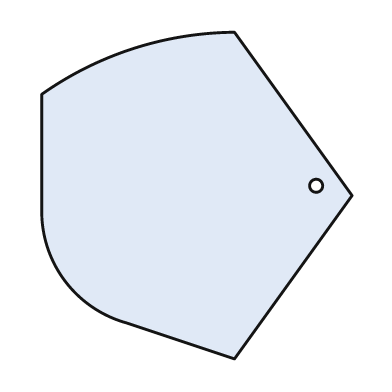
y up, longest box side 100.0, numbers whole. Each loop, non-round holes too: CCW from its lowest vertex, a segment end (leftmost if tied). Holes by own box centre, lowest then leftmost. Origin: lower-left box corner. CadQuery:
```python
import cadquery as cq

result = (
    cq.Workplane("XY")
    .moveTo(59.0, 0.0)
    .lineTo(95.0, 50.0)
    .lineTo(59.0, 100.0)
    .threePointArc((28.0, 95.0), (0.0, 81.0))
    .lineTo(0.0, 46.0)
    .threePointArc((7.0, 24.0), (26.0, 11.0))
    .close()
    .moveTo(84.0, 53.0)
    .circle(2.0)
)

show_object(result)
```